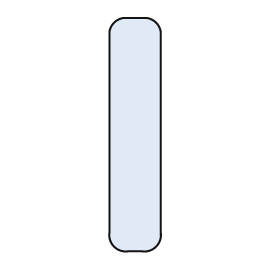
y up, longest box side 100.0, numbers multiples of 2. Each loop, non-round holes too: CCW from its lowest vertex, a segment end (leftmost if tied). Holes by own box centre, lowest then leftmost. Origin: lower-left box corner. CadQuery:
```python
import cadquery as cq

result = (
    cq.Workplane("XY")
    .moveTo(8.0, 0.0)
    .lineTo(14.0, 0.0)
    .threePointArc((20.0, 2.0), (22.0, 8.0))
    .lineTo(22.0, 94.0)
    .threePointArc((20.0, 98.0), (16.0, 100.0))
    .lineTo(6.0, 100.0)
    .threePointArc((2.0, 98.0), (0.0, 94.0))
    .lineTo(0.0, 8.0)
    .threePointArc((2.0, 2.0), (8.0, 0.0))
    .close()
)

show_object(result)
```